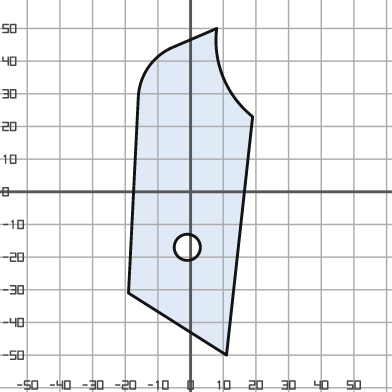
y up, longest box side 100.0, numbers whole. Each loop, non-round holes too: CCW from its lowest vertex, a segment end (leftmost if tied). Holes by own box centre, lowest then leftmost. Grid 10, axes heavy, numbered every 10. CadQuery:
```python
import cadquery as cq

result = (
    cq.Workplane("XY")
    .moveTo(11.0, -50.0)
    .lineTo(19.0, 23.0)
    .threePointArc((10.0, 35.0), (8.0, 50.0))
    .lineTo(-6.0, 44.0)
    .threePointArc((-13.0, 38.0), (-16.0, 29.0))
    .lineTo(-19.0, -31.0)
    .close()
    .moveTo(-1.0, -17.0)
    .circle(4.0)
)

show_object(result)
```